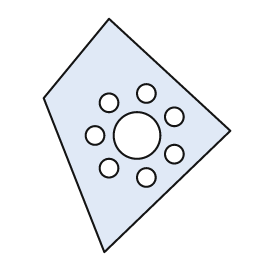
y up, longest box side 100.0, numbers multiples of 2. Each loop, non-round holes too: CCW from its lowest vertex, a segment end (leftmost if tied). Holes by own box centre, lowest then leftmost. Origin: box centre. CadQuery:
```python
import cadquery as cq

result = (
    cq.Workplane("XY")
    .moveTo(-14.0, -50.0)
    .lineTo(40.0, 2.0)
    .lineTo(-12.0, 50.0)
    .lineTo(-40.0, 16.0)
    .close()
    .moveTo(4.0, -18.0)
    .circle(4.0)
    .moveTo(-12.0, -14.0)
    .circle(4.0)
    .moveTo(16.0, -8.0)
    .circle(4.0)
    .moveTo(-18.0, 0.0)
    .circle(4.0)
    .moveTo(0.0, 0.0)
    .circle(10.0)
    .moveTo(16.0, 8.0)
    .circle(4.0)
    .moveTo(-12.0, 14.0)
    .circle(4.0)
    .moveTo(4.0, 18.0)
    .circle(4.0)
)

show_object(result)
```